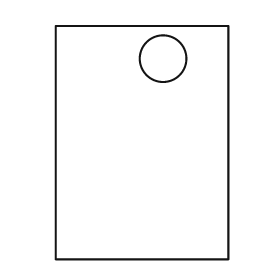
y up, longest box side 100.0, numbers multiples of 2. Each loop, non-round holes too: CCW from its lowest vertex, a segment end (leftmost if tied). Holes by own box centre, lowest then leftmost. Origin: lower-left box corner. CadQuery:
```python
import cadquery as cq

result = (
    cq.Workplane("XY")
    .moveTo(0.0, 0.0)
    .lineTo(74.0, 0.0)
    .lineTo(74.0, 100.0)
    .lineTo(0.0, 100.0)
    .close()
    .moveTo(46.0, 86.0)
    .circle(10.0)
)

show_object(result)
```